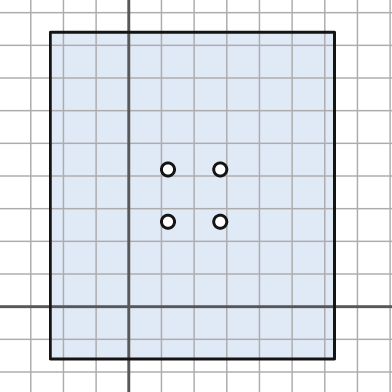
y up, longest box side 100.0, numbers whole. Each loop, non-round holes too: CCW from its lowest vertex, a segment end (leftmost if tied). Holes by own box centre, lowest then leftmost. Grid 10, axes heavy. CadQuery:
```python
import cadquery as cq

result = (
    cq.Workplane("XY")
    .moveTo(-24.0, -16.0)
    .lineTo(63.0, -16.0)
    .lineTo(63.0, 84.0)
    .lineTo(-24.0, 84.0)
    .close()
    .moveTo(12.0, 26.0)
    .circle(2.0)
    .moveTo(28.0, 26.0)
    .circle(2.0)
    .moveTo(12.0, 42.0)
    .circle(2.0)
    .moveTo(28.0, 42.0)
    .circle(2.0)
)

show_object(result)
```